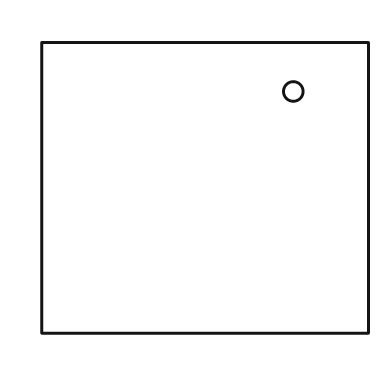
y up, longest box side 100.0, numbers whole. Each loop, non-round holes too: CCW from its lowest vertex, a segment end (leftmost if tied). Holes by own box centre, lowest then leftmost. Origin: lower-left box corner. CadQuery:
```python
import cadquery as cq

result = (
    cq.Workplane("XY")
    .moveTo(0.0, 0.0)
    .lineTo(100.0, 0.0)
    .lineTo(100.0, 89.0)
    .lineTo(0.0, 89.0)
    .close()
    .moveTo(77.0, 74.0)
    .circle(3.0)
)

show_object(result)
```